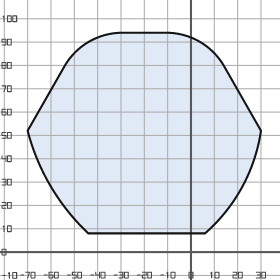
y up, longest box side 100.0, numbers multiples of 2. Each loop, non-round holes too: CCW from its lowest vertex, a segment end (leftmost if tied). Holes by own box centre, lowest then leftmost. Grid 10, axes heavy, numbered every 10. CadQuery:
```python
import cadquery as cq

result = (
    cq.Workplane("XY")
    .moveTo(-44.0, 8.0)
    .lineTo(6.0, 8.0)
    .threePointArc((22.0, 28.0), (30.0, 52.0))
    .lineTo(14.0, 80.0)
    .threePointArc((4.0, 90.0), (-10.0, 94.0))
    .lineTo(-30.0, 94.0)
    .threePointArc((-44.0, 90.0), (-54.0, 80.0))
    .lineTo(-70.0, 52.0)
    .threePointArc((-60.0, 28.0), (-44.0, 8.0))
    .close()
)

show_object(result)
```